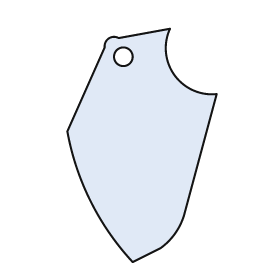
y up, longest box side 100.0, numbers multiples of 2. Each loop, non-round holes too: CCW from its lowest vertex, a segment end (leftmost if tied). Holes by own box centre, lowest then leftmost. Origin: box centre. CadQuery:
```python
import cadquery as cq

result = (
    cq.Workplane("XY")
    .moveTo(-4.0, -50.0)
    .lineTo(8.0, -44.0)
    .threePointArc((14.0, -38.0), (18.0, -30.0))
    .lineTo(32.0, 22.0)
    .threePointArc((14.0, 30.0), (12.0, 50.0))
    .lineTo(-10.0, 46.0)
    .threePointArc((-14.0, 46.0), (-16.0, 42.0))
    .lineTo(-32.0, 6.0)
    .threePointArc((-22.0, -24.0), (-4.0, -50.0))
    .close()
    .moveTo(-8.0, 38.0)
    .circle(4.0)
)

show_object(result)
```